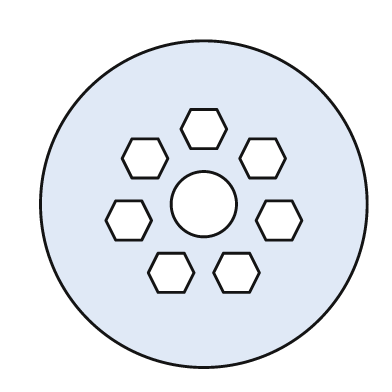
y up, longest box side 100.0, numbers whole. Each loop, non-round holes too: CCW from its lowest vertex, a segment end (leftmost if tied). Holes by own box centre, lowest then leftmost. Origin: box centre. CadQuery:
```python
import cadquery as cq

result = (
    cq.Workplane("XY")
    .moveTo(0.0, 0.0)
    .circle(50.0)
    .moveTo(-14.0, -27.0)
    .lineTo(-6.0, -27.0)
    .lineTo(-3.0, -21.0)
    .lineTo(-6.0, -15.0)
    .lineTo(-14.0, -15.0)
    .lineTo(-17.0, -21.0)
    .close()
    .moveTo(6.0, -27.0)
    .lineTo(14.0, -27.0)
    .lineTo(17.0, -21.0)
    .lineTo(14.0, -15.0)
    .lineTo(6.0, -15.0)
    .lineTo(3.0, -21.0)
    .close()
    .moveTo(-27.0, -11.0)
    .lineTo(-19.0, -11.0)
    .lineTo(-16.0, -5.0)
    .lineTo(-19.0, 1.0)
    .lineTo(-27.0, 1.0)
    .lineTo(-30.0, -5.0)
    .close()
    .moveTo(19.0, -11.0)
    .lineTo(27.0, -11.0)
    .lineTo(30.0, -5.0)
    .lineTo(27.0, 1.0)
    .lineTo(19.0, 1.0)
    .lineTo(16.0, -5.0)
    .close()
    .moveTo(0.0, 0.0)
    .circle(10.0)
    .moveTo(-22.0, 8.0)
    .lineTo(-14.0, 8.0)
    .lineTo(-11.0, 14.0)
    .lineTo(-14.0, 20.0)
    .lineTo(-22.0, 20.0)
    .lineTo(-25.0, 14.0)
    .close()
    .moveTo(14.0, 8.0)
    .lineTo(22.0, 8.0)
    .lineTo(25.0, 14.0)
    .lineTo(22.0, 20.0)
    .lineTo(14.0, 20.0)
    .lineTo(11.0, 14.0)
    .close()
    .moveTo(-4.0, 17.0)
    .lineTo(4.0, 17.0)
    .lineTo(7.0, 23.0)
    .lineTo(4.0, 29.0)
    .lineTo(-4.0, 29.0)
    .lineTo(-7.0, 23.0)
    .close()
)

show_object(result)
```